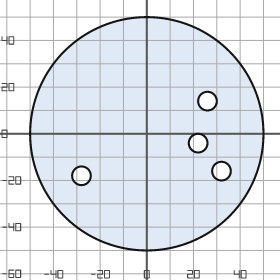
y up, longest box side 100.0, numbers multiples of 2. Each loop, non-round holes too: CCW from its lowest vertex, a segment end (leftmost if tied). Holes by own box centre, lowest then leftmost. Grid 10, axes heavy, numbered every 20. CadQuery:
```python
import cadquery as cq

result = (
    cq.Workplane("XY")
    .moveTo(0.0, 0.0)
    .circle(50.0)
    .moveTo(-28.0, -18.0)
    .circle(4.0)
    .moveTo(32.0, -16.0)
    .circle(4.0)
    .moveTo(22.0, -4.0)
    .circle(4.0)
    .moveTo(26.0, 14.0)
    .circle(4.0)
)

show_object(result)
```